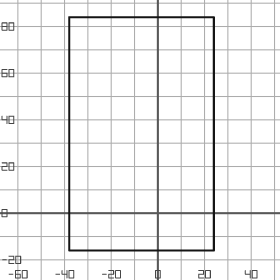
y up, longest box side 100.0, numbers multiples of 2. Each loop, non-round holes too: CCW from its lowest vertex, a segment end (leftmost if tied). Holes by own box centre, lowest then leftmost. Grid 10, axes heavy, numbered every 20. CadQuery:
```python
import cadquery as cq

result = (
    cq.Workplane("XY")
    .moveTo(-38.0, -16.0)
    .lineTo(24.0, -16.0)
    .lineTo(24.0, 84.0)
    .lineTo(-38.0, 84.0)
    .close()
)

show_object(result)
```